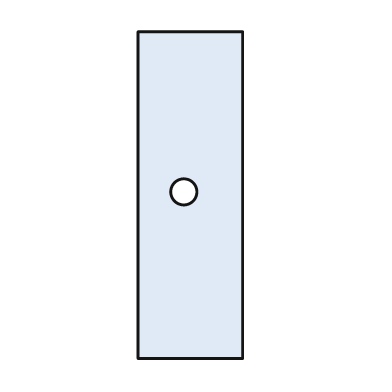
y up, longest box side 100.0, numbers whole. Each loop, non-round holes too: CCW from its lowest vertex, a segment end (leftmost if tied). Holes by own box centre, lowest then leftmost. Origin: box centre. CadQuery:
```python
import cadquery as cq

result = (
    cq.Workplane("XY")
    .moveTo(-16.0, -50.0)
    .lineTo(16.0, -50.0)
    .lineTo(16.0, 50.0)
    .lineTo(-16.0, 50.0)
    .close()
    .moveTo(-2.0, 1.0)
    .circle(4.0)
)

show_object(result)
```